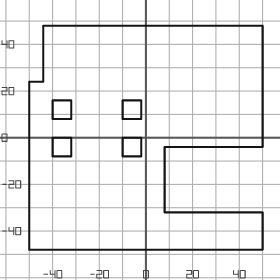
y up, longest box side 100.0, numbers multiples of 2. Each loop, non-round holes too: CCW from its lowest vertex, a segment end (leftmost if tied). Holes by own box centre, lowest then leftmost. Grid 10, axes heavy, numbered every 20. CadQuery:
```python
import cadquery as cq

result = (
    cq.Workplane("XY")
    .moveTo(-50.0, -48.0)
    .lineTo(50.0, -48.0)
    .lineTo(50.0, -32.0)
    .lineTo(8.0, -32.0)
    .lineTo(8.0, -4.0)
    .lineTo(50.0, -4.0)
    .lineTo(50.0, 48.0)
    .lineTo(-44.0, 48.0)
    .lineTo(-44.0, 24.0)
    .lineTo(-50.0, 24.0)
    .close()
    .moveTo(-40.0, -8.0)
    .lineTo(-32.0, -8.0)
    .lineTo(-32.0, 0.0)
    .lineTo(-40.0, 0.0)
    .close()
    .moveTo(-10.0, -8.0)
    .lineTo(-2.0, -8.0)
    .lineTo(-2.0, 0.0)
    .lineTo(-10.0, 0.0)
    .close()
    .moveTo(-40.0, 8.0)
    .lineTo(-32.0, 8.0)
    .lineTo(-32.0, 16.0)
    .lineTo(-40.0, 16.0)
    .close()
    .moveTo(-10.0, 8.0)
    .lineTo(-2.0, 8.0)
    .lineTo(-2.0, 16.0)
    .lineTo(-10.0, 16.0)
    .close()
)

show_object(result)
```